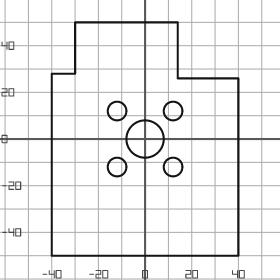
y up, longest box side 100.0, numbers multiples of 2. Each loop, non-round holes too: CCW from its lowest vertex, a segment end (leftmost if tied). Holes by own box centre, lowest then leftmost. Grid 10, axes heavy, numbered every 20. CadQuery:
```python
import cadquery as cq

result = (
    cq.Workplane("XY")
    .moveTo(-40.0, -50.0)
    .lineTo(40.0, -50.0)
    .lineTo(40.0, 26.0)
    .lineTo(14.0, 26.0)
    .lineTo(14.0, 50.0)
    .lineTo(-30.0, 50.0)
    .lineTo(-30.0, 28.0)
    .lineTo(-40.0, 28.0)
    .close()
    .moveTo(-12.0, -12.0)
    .circle(4.0)
    .moveTo(12.0, -12.0)
    .circle(4.0)
    .moveTo(0.0, 0.0)
    .circle(8.0)
    .moveTo(-12.0, 12.0)
    .circle(4.0)
    .moveTo(12.0, 12.0)
    .circle(4.0)
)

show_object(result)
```